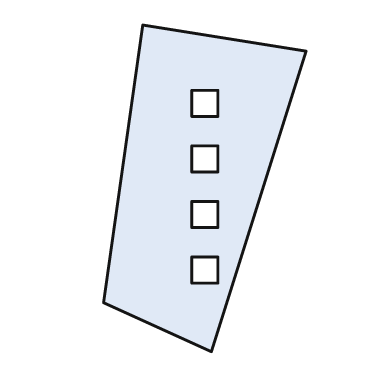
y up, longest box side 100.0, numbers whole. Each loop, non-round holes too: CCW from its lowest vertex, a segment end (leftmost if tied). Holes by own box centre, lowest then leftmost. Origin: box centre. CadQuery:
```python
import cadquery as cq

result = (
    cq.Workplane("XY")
    .moveTo(2.0, -50.0)
    .lineTo(31.0, 42.0)
    .lineTo(-19.0, 50.0)
    .lineTo(-31.0, -35.0)
    .close()
    .moveTo(-4.0, -29.0)
    .lineTo(4.0, -29.0)
    .lineTo(4.0, -21.0)
    .lineTo(-4.0, -21.0)
    .close()
    .moveTo(-4.0, -12.0)
    .lineTo(4.0, -12.0)
    .lineTo(4.0, -4.0)
    .lineTo(-4.0, -4.0)
    .close()
    .moveTo(-4.0, 5.0)
    .lineTo(4.0, 5.0)
    .lineTo(4.0, 13.0)
    .lineTo(-4.0, 13.0)
    .close()
    .moveTo(-4.0, 22.0)
    .lineTo(4.0, 22.0)
    .lineTo(4.0, 30.0)
    .lineTo(-4.0, 30.0)
    .close()
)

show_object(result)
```